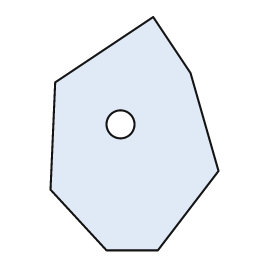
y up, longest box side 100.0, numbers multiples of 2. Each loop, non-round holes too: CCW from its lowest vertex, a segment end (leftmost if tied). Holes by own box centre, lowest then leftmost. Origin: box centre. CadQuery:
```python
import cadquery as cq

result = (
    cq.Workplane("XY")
    .moveTo(-12.0, -50.0)
    .lineTo(10.0, -50.0)
    .lineTo(36.0, -16.0)
    .lineTo(24.0, 26.0)
    .lineTo(8.0, 50.0)
    .lineTo(-34.0, 22.0)
    .lineTo(-36.0, -24.0)
    .close()
    .moveTo(-6.0, 4.0)
    .circle(6.0)
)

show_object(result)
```